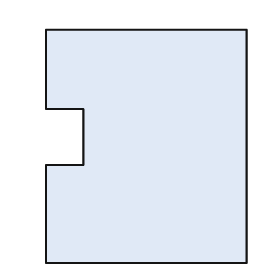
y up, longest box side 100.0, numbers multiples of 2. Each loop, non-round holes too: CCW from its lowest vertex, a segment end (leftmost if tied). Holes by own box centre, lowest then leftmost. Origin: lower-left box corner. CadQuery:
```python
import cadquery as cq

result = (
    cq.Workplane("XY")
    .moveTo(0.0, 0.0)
    .lineTo(86.0, 0.0)
    .lineTo(86.0, 100.0)
    .lineTo(0.0, 100.0)
    .lineTo(0.0, 66.0)
    .lineTo(16.0, 66.0)
    .lineTo(16.0, 42.0)
    .lineTo(0.0, 42.0)
    .close()
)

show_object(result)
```